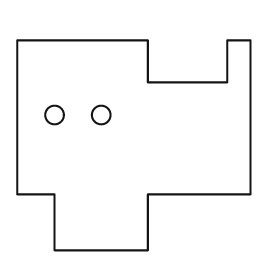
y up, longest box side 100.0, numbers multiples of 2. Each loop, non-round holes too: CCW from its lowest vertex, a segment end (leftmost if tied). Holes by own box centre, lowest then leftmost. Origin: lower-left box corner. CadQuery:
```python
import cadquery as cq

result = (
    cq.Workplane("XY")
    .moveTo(16.0, 0.0)
    .lineTo(56.0, 0.0)
    .lineTo(56.0, 24.0)
    .lineTo(100.0, 24.0)
    .lineTo(100.0, 90.0)
    .lineTo(90.0, 90.0)
    .lineTo(90.0, 72.0)
    .lineTo(56.0, 72.0)
    .lineTo(56.0, 90.0)
    .lineTo(0.0, 90.0)
    .lineTo(0.0, 24.0)
    .lineTo(16.0, 24.0)
    .close()
    .moveTo(16.0, 58.0)
    .circle(4.0)
    .moveTo(36.0, 58.0)
    .circle(4.0)
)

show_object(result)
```